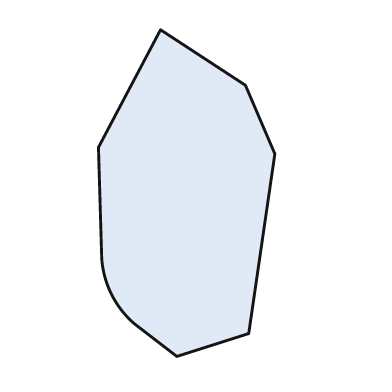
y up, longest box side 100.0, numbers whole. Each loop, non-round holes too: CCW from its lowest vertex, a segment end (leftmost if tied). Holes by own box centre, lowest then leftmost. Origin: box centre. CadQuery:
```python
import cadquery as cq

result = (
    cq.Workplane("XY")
    .moveTo(-3.0, -50.0)
    .lineTo(19.0, -43.0)
    .lineTo(27.0, 12.0)
    .lineTo(18.0, 33.0)
    .lineTo(-8.0, 50.0)
    .lineTo(-27.0, 14.0)
    .lineTo(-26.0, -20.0)
    .threePointArc((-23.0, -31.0), (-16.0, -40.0))
    .close()
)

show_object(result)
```